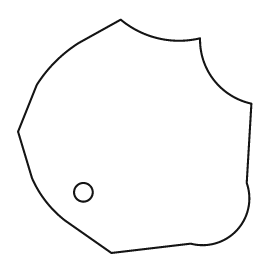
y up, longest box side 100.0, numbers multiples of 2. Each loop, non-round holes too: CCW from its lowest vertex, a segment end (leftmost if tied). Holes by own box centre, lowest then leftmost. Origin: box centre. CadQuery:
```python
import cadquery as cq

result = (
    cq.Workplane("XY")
    .moveTo(-10.0, -50.0)
    .lineTo(24.0, -46.0)
    .threePointArc((44.0, -40.0), (48.0, -20.0))
    .lineTo(50.0, 14.0)
    .threePointArc((34.0, 24.0), (28.0, 42.0))
    .threePointArc((10.0, 42.0), (-6.0, 50.0))
    .lineTo(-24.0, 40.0)
    .threePointArc((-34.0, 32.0), (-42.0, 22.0))
    .lineTo(-50.0, 2.0)
    .lineTo(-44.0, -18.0)
    .threePointArc((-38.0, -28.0), (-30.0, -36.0))
    .close()
    .moveTo(-22.0, -24.0)
    .circle(4.0)
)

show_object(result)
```